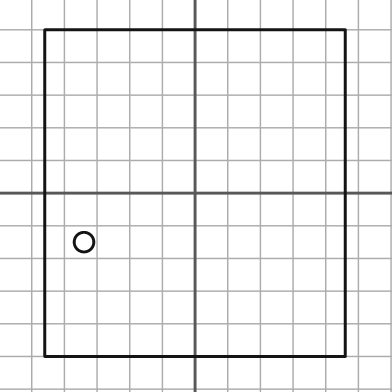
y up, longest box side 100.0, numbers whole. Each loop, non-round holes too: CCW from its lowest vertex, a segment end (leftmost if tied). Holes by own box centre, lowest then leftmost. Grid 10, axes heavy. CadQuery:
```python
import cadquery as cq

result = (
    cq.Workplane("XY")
    .moveTo(-46.0, -50.0)
    .lineTo(46.0, -50.0)
    .lineTo(46.0, 50.0)
    .lineTo(-46.0, 50.0)
    .close()
    .moveTo(-34.0, -15.0)
    .circle(3.0)
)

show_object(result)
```